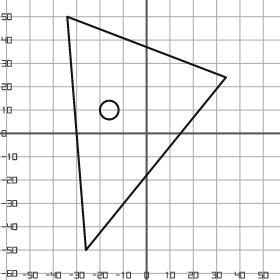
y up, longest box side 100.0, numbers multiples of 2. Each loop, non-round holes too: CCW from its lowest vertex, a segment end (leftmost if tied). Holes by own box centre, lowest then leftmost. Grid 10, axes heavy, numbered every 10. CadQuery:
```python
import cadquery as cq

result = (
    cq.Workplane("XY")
    .moveTo(-26.0, -50.0)
    .lineTo(34.0, 24.0)
    .lineTo(-34.0, 50.0)
    .close()
    .moveTo(-16.0, 10.0)
    .circle(4.0)
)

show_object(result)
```